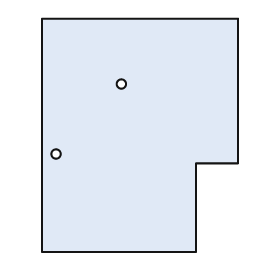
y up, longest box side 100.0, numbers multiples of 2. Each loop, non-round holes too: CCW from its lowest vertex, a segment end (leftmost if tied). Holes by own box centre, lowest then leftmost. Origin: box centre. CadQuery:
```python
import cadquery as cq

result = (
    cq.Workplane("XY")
    .moveTo(-42.0, -50.0)
    .lineTo(24.0, -50.0)
    .lineTo(24.0, -12.0)
    .lineTo(42.0, -12.0)
    .lineTo(42.0, 50.0)
    .lineTo(-42.0, 50.0)
    .close()
    .moveTo(-36.0, -8.0)
    .circle(2.0)
    .moveTo(-8.0, 22.0)
    .circle(2.0)
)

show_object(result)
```